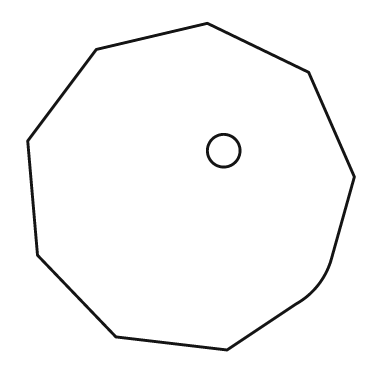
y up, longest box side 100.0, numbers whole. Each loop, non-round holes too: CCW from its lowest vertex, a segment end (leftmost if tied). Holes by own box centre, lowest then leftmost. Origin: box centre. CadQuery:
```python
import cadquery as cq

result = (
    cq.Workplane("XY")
    .moveTo(11.0, -50.0)
    .lineTo(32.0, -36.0)
    .threePointArc((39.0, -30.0), (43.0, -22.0))
    .lineTo(50.0, 3.0)
    .lineTo(36.0, 35.0)
    .lineTo(5.0, 50.0)
    .lineTo(-29.0, 42.0)
    .lineTo(-50.0, 14.0)
    .lineTo(-47.0, -21.0)
    .lineTo(-23.0, -46.0)
    .close()
    .moveTo(10.0, 11.0)
    .circle(5.0)
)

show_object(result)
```